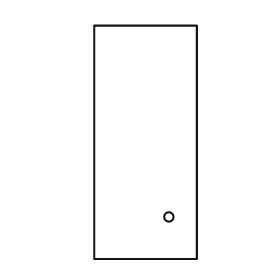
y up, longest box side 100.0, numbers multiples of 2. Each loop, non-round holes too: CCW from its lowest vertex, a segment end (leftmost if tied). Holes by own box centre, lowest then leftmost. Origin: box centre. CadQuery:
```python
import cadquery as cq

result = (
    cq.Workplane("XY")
    .moveTo(-22.0, -50.0)
    .lineTo(22.0, -50.0)
    .lineTo(22.0, 50.0)
    .lineTo(-22.0, 50.0)
    .close()
    .moveTo(10.0, -32.0)
    .circle(2.0)
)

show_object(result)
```